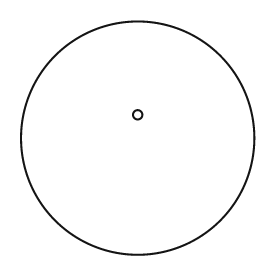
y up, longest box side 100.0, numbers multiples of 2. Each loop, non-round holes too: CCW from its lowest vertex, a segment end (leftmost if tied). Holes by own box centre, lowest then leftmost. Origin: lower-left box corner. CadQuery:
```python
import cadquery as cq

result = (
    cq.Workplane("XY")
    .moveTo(50.0, 50.0)
    .circle(50.0)
    .moveTo(50.0, 60.0)
    .circle(2.0)
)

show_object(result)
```